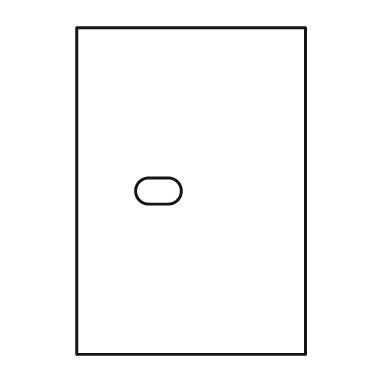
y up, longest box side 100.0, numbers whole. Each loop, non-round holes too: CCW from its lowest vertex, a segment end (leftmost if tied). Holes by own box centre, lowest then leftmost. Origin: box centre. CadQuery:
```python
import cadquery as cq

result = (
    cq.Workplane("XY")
    .moveTo(-35.0, -50.0)
    .lineTo(35.0, -50.0)
    .lineTo(35.0, 50.0)
    .lineTo(-35.0, 50.0)
    .close()
    .moveTo(-13.0, -4.0)
    .lineTo(-7.0, -4.0)
    .threePointArc((-3.0, 0.0), (-7.0, 4.0))
    .lineTo(-13.0, 4.0)
    .threePointArc((-17.0, 0.0), (-13.0, -4.0))
    .close()
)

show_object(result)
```